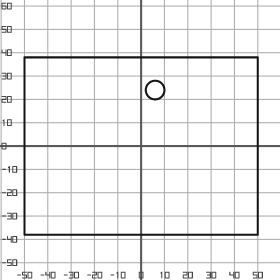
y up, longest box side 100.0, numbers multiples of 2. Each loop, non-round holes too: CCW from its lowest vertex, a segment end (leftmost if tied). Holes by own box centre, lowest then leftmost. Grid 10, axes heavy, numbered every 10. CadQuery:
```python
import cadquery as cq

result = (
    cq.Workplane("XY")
    .moveTo(-50.0, -38.0)
    .lineTo(50.0, -38.0)
    .lineTo(50.0, 38.0)
    .lineTo(-50.0, 38.0)
    .close()
    .moveTo(6.0, 24.0)
    .circle(4.0)
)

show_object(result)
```